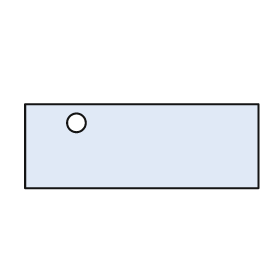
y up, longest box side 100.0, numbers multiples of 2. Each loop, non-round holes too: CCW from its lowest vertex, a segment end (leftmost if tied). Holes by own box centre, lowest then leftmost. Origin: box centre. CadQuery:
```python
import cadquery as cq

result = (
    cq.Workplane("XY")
    .moveTo(-50.0, -18.0)
    .lineTo(50.0, -18.0)
    .lineTo(50.0, 18.0)
    .lineTo(-50.0, 18.0)
    .close()
    .moveTo(-28.0, 10.0)
    .circle(4.0)
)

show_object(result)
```